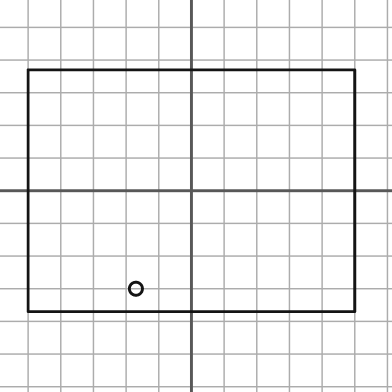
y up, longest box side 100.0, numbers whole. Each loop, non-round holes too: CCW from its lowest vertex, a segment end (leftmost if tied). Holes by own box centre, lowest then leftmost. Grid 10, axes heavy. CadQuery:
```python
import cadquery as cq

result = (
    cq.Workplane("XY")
    .moveTo(-50.0, -37.0)
    .lineTo(50.0, -37.0)
    .lineTo(50.0, 37.0)
    .lineTo(-50.0, 37.0)
    .close()
    .moveTo(-17.0, -30.0)
    .circle(2.0)
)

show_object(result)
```